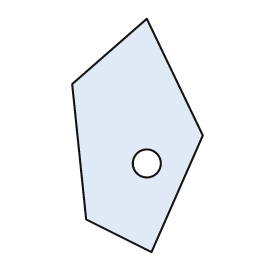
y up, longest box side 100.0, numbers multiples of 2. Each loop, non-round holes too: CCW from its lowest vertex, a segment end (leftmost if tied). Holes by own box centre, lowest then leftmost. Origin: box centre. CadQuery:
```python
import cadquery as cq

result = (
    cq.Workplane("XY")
    .moveTo(6.0, -50.0)
    .lineTo(28.0, 0.0)
    .lineTo(4.0, 50.0)
    .lineTo(-28.0, 22.0)
    .lineTo(-22.0, -36.0)
    .close()
    .moveTo(4.0, -12.0)
    .circle(6.0)
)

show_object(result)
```